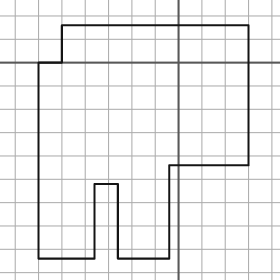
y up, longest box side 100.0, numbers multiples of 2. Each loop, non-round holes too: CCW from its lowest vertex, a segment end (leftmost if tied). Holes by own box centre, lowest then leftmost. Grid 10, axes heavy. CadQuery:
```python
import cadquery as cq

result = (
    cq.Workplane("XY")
    .moveTo(-60.0, -84.0)
    .lineTo(-36.0, -84.0)
    .lineTo(-36.0, -52.0)
    .lineTo(-26.0, -52.0)
    .lineTo(-26.0, -84.0)
    .lineTo(-4.0, -84.0)
    .lineTo(-4.0, -44.0)
    .lineTo(30.0, -44.0)
    .lineTo(30.0, 16.0)
    .lineTo(-50.0, 16.0)
    .lineTo(-50.0, 0.0)
    .lineTo(-60.0, 0.0)
    .close()
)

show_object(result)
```